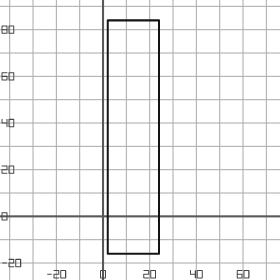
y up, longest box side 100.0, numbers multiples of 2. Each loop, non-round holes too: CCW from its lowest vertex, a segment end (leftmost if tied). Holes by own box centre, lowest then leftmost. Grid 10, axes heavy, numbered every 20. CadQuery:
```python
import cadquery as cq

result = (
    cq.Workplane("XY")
    .moveTo(2.0, -16.0)
    .lineTo(24.0, -16.0)
    .lineTo(24.0, 84.0)
    .lineTo(2.0, 84.0)
    .close()
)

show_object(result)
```